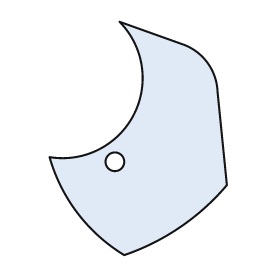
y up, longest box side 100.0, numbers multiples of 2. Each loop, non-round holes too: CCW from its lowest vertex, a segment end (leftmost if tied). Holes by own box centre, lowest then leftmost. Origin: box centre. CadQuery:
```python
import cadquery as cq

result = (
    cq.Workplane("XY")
    .moveTo(-6.0, -50.0)
    .threePointArc((18.0, -38.0), (38.0, -20.0))
    .lineTo(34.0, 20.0)
    .threePointArc((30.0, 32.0), (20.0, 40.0))
    .lineTo(-8.0, 50.0)
    .threePointArc((-2.0, 10.0), (-38.0, -8.0))
    .threePointArc((-26.0, -32.0), (-6.0, -50.0))
    .close()
    .moveTo(-10.0, -10.0)
    .circle(4.0)
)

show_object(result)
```